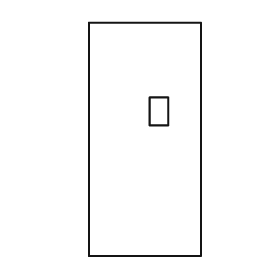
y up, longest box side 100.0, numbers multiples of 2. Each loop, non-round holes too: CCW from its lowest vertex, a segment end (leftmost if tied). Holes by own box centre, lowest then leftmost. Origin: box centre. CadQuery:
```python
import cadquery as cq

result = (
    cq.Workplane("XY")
    .moveTo(-24.0, -50.0)
    .lineTo(24.0, -50.0)
    .lineTo(24.0, 50.0)
    .lineTo(-24.0, 50.0)
    .close()
    .moveTo(2.0, 6.0)
    .lineTo(10.0, 6.0)
    .lineTo(10.0, 18.0)
    .lineTo(2.0, 18.0)
    .close()
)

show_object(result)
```